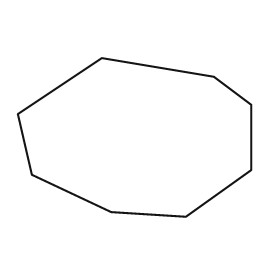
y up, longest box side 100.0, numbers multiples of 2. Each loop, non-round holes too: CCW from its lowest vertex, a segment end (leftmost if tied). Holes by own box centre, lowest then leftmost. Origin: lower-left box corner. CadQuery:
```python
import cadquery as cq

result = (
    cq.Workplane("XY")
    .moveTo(72.0, 0.0)
    .lineTo(100.0, 20.0)
    .lineTo(100.0, 48.0)
    .lineTo(84.0, 60.0)
    .lineTo(36.0, 68.0)
    .lineTo(0.0, 44.0)
    .lineTo(6.0, 18.0)
    .lineTo(40.0, 2.0)
    .close()
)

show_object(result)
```